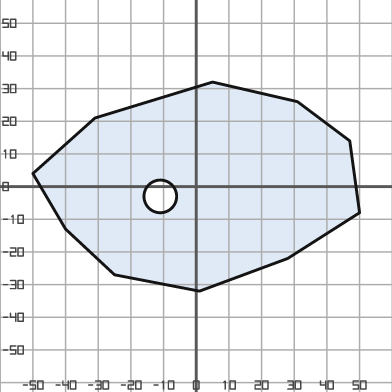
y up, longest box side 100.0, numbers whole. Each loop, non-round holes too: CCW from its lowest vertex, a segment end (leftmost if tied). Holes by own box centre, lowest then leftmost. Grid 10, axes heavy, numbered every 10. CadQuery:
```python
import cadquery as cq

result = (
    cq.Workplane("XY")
    .moveTo(1.0, -32.0)
    .lineTo(28.0, -22.0)
    .lineTo(50.0, -8.0)
    .lineTo(47.0, 14.0)
    .lineTo(31.0, 26.0)
    .lineTo(5.0, 32.0)
    .lineTo(-31.0, 21.0)
    .lineTo(-50.0, 4.0)
    .lineTo(-40.0, -13.0)
    .lineTo(-25.0, -27.0)
    .close()
    .moveTo(-11.0, -3.0)
    .circle(5.0)
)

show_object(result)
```